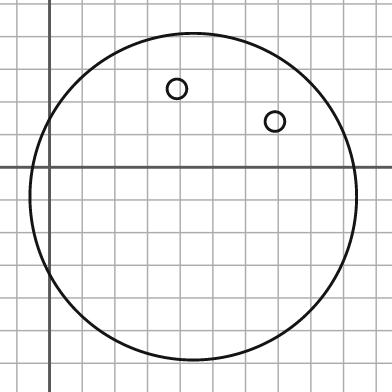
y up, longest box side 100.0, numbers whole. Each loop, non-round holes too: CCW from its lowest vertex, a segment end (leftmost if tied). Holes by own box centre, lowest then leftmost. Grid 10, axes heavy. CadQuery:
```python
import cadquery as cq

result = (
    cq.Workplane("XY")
    .moveTo(44.0, -9.0)
    .circle(50.0)
    .moveTo(69.0, 14.0)
    .circle(3.0)
    .moveTo(39.0, 24.0)
    .circle(3.0)
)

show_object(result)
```